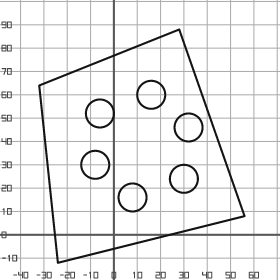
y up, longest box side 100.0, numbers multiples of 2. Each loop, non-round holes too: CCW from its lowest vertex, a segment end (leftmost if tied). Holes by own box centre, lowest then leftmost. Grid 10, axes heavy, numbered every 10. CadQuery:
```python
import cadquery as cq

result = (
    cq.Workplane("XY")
    .moveTo(-24.0, -12.0)
    .lineTo(56.0, 8.0)
    .lineTo(28.0, 88.0)
    .lineTo(-32.0, 64.0)
    .close()
    .moveTo(8.0, 16.0)
    .circle(6.0)
    .moveTo(30.0, 24.0)
    .circle(6.0)
    .moveTo(-8.0, 30.0)
    .circle(6.0)
    .moveTo(32.0, 46.0)
    .circle(6.0)
    .moveTo(-6.0, 52.0)
    .circle(6.0)
    .moveTo(16.0, 60.0)
    .circle(6.0)
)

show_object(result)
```